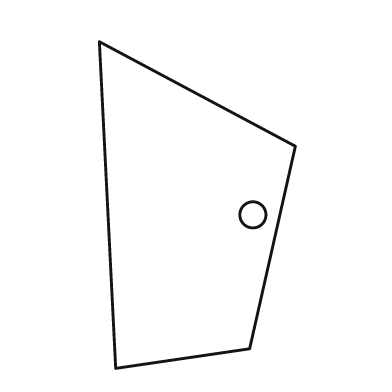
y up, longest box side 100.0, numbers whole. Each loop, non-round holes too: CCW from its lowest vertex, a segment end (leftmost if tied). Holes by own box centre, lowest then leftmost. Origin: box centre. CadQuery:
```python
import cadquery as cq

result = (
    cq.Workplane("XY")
    .moveTo(-25.0, -50.0)
    .lineTo(16.0, -44.0)
    .lineTo(30.0, 18.0)
    .lineTo(-30.0, 50.0)
    .close()
    .moveTo(17.0, -3.0)
    .circle(4.0)
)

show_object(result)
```